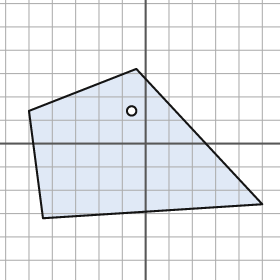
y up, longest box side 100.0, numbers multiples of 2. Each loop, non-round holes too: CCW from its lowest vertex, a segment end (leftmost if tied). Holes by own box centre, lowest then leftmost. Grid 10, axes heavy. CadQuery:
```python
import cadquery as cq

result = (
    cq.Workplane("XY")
    .moveTo(-44.0, -32.0)
    .lineTo(50.0, -26.0)
    .lineTo(-4.0, 32.0)
    .lineTo(-50.0, 14.0)
    .close()
    .moveTo(-6.0, 14.0)
    .circle(2.0)
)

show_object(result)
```